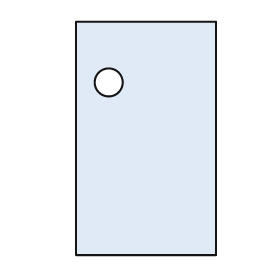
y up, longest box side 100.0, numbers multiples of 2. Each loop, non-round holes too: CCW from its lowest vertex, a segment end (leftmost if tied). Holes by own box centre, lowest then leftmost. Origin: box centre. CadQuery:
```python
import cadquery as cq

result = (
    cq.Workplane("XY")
    .moveTo(-30.0, -50.0)
    .lineTo(30.0, -50.0)
    .lineTo(30.0, 50.0)
    .lineTo(-30.0, 50.0)
    .close()
    .moveTo(-16.0, 24.0)
    .circle(6.0)
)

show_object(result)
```